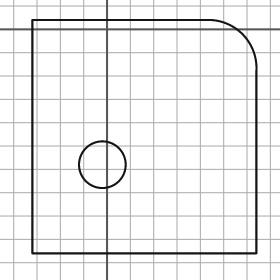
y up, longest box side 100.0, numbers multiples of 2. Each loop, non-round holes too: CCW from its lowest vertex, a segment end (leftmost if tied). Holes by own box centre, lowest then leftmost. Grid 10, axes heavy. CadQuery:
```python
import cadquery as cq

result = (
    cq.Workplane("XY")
    .moveTo(-32.0, -96.0)
    .lineTo(64.0, -96.0)
    .lineTo(64.0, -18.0)
    .threePointArc((58.0, -2.0), (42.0, 4.0))
    .lineTo(-32.0, 4.0)
    .close()
    .moveTo(-2.0, -58.0)
    .circle(10.0)
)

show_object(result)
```